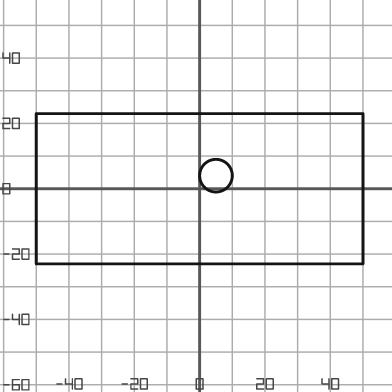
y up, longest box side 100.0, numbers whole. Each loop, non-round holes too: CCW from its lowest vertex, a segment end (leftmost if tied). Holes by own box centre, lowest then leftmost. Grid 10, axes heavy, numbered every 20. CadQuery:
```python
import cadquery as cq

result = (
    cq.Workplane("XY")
    .moveTo(-50.0, -23.0)
    .lineTo(50.0, -23.0)
    .lineTo(50.0, 23.0)
    .lineTo(-50.0, 23.0)
    .close()
    .moveTo(5.0, 4.0)
    .circle(5.0)
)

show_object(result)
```